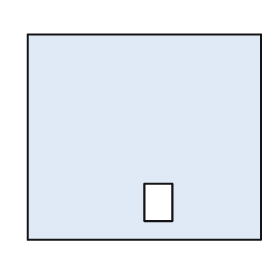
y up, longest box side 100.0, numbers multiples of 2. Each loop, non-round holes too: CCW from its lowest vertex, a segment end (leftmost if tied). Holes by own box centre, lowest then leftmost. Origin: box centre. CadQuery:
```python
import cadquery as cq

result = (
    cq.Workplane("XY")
    .moveTo(-50.0, -44.0)
    .lineTo(50.0, -44.0)
    .lineTo(50.0, 44.0)
    .lineTo(-50.0, 44.0)
    .close()
    .moveTo(0.0, -36.0)
    .lineTo(12.0, -36.0)
    .lineTo(12.0, -20.0)
    .lineTo(0.0, -20.0)
    .close()
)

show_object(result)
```